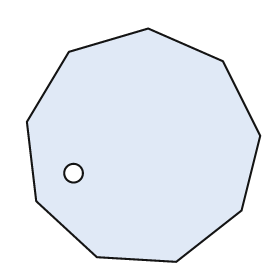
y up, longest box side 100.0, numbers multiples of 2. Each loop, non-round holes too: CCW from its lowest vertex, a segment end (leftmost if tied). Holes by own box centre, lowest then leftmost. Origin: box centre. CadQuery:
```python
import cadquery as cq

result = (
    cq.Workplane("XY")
    .moveTo(14.0, -50.0)
    .lineTo(42.0, -28.0)
    .lineTo(50.0, 4.0)
    .lineTo(34.0, 36.0)
    .lineTo(2.0, 50.0)
    .lineTo(-32.0, 40.0)
    .lineTo(-50.0, 10.0)
    .lineTo(-46.0, -24.0)
    .lineTo(-20.0, -48.0)
    .close()
    .moveTo(-30.0, -12.0)
    .circle(4.0)
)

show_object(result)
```